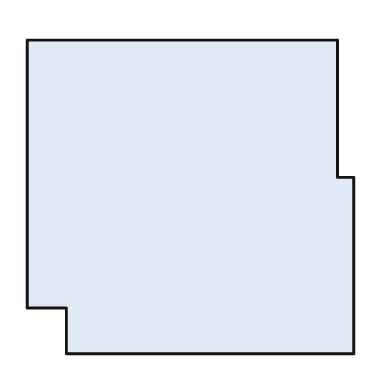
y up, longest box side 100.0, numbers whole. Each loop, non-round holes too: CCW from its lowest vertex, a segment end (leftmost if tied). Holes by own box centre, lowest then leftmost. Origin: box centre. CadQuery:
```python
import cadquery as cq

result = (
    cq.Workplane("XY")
    .moveTo(-38.0, -48.0)
    .lineTo(50.0, -48.0)
    .lineTo(50.0, 6.0)
    .lineTo(45.0, 6.0)
    .lineTo(45.0, 48.0)
    .lineTo(-50.0, 48.0)
    .lineTo(-50.0, -34.0)
    .lineTo(-38.0, -34.0)
    .close()
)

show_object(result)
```